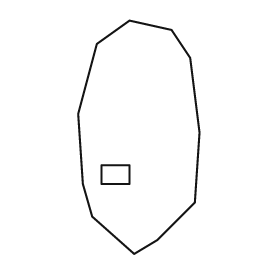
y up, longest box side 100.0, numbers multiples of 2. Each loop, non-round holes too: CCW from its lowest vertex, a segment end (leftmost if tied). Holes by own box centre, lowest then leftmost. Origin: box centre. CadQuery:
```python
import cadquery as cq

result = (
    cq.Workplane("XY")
    .moveTo(-2.0, -50.0)
    .lineTo(8.0, -44.0)
    .lineTo(24.0, -28.0)
    .lineTo(26.0, 2.0)
    .lineTo(22.0, 34.0)
    .lineTo(14.0, 46.0)
    .lineTo(-4.0, 50.0)
    .lineTo(-18.0, 40.0)
    .lineTo(-26.0, 10.0)
    .lineTo(-24.0, -20.0)
    .lineTo(-20.0, -34.0)
    .close()
    .moveTo(-16.0, -20.0)
    .lineTo(-4.0, -20.0)
    .lineTo(-4.0, -12.0)
    .lineTo(-16.0, -12.0)
    .close()
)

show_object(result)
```